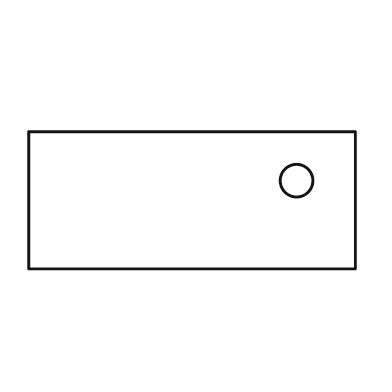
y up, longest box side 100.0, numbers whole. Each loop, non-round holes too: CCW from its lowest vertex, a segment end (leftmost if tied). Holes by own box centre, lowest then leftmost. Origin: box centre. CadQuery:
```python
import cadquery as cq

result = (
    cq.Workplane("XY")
    .moveTo(-50.0, -21.0)
    .lineTo(50.0, -21.0)
    .lineTo(50.0, 21.0)
    .lineTo(-50.0, 21.0)
    .close()
    .moveTo(32.0, 6.0)
    .circle(5.0)
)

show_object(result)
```